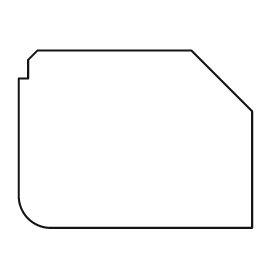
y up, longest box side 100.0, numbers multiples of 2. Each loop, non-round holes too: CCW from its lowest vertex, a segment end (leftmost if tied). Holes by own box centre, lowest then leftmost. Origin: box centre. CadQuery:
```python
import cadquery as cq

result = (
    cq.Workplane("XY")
    .moveTo(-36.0, -38.0)
    .lineTo(50.0, -38.0)
    .lineTo(50.0, 12.0)
    .lineTo(24.0, 38.0)
    .lineTo(-42.0, 38.0)
    .lineTo(-46.0, 34.0)
    .lineTo(-46.0, 26.0)
    .lineTo(-50.0, 26.0)
    .lineTo(-50.0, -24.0)
    .threePointArc((-46.0, -34.0), (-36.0, -38.0))
    .close()
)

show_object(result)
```